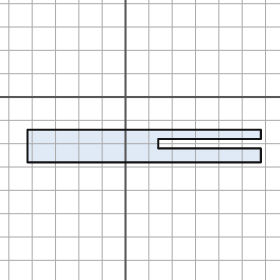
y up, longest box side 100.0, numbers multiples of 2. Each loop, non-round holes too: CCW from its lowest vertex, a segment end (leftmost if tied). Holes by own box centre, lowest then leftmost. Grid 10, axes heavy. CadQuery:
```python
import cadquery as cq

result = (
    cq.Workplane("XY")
    .moveTo(-42.0, -28.0)
    .lineTo(58.0, -28.0)
    .lineTo(58.0, -22.0)
    .lineTo(14.0, -22.0)
    .lineTo(14.0, -18.0)
    .lineTo(58.0, -18.0)
    .lineTo(58.0, -14.0)
    .lineTo(-42.0, -14.0)
    .close()
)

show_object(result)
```